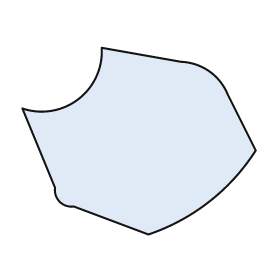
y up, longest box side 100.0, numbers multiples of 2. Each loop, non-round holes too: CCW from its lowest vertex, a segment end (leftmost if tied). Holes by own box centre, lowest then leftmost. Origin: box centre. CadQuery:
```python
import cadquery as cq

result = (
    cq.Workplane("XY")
    .moveTo(4.0, -40.0)
    .threePointArc((30.0, -26.0), (50.0, -4.0))
    .lineTo(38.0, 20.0)
    .threePointArc((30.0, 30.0), (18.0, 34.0))
    .lineTo(-16.0, 40.0)
    .threePointArc((-26.0, 18.0), (-50.0, 14.0))
    .lineTo(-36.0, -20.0)
    .threePointArc((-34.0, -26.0), (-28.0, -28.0))
    .close()
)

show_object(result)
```